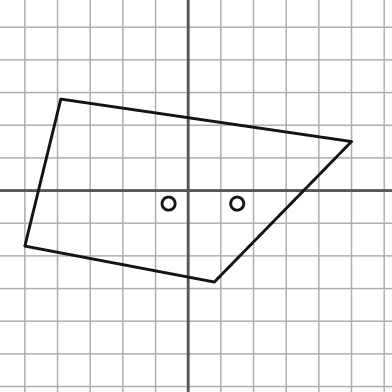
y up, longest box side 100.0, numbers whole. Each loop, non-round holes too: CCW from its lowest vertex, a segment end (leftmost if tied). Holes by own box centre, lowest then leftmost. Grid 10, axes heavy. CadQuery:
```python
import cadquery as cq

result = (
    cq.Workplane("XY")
    .moveTo(8.0, -28.0)
    .lineTo(50.0, 15.0)
    .lineTo(-39.0, 28.0)
    .lineTo(-50.0, -17.0)
    .close()
    .moveTo(-6.0, -4.0)
    .circle(2.0)
    .moveTo(15.0, -4.0)
    .circle(2.0)
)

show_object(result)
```